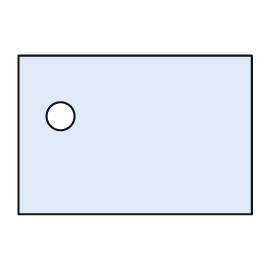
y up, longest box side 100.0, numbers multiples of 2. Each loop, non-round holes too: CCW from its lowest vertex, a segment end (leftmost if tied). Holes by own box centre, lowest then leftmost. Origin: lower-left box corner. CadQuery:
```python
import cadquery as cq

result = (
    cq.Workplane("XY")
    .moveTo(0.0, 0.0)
    .lineTo(100.0, 0.0)
    .lineTo(100.0, 68.0)
    .lineTo(0.0, 68.0)
    .close()
    .moveTo(18.0, 42.0)
    .circle(6.0)
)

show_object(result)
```